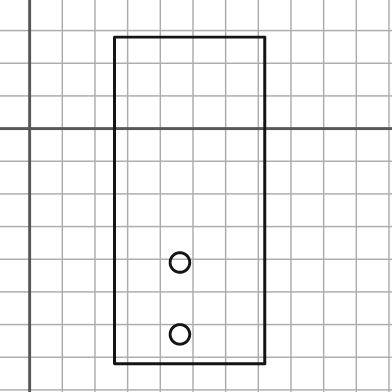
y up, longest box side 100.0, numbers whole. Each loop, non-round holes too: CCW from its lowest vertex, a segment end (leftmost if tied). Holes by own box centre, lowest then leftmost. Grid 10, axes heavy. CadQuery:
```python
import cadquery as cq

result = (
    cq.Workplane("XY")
    .moveTo(26.0, -72.0)
    .lineTo(72.0, -72.0)
    .lineTo(72.0, 28.0)
    .lineTo(26.0, 28.0)
    .close()
    .moveTo(46.0, -63.0)
    .circle(3.0)
    .moveTo(46.0, -41.0)
    .circle(3.0)
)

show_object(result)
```